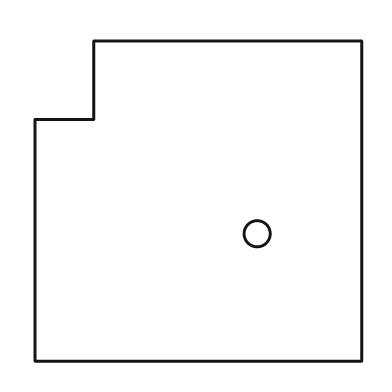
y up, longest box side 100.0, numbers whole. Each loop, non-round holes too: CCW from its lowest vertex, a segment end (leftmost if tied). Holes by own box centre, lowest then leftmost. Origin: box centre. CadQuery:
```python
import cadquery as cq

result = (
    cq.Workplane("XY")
    .moveTo(-50.0, -49.0)
    .lineTo(50.0, -49.0)
    .lineTo(50.0, 49.0)
    .lineTo(-32.0, 49.0)
    .lineTo(-32.0, 25.0)
    .lineTo(-50.0, 25.0)
    .close()
    .moveTo(18.0, -10.0)
    .circle(4.0)
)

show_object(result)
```